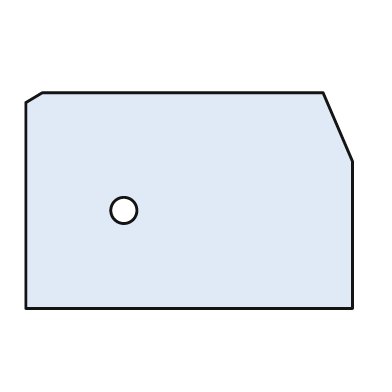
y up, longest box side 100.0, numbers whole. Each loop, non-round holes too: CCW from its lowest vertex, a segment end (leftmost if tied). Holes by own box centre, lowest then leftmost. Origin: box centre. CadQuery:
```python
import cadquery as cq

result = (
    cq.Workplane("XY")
    .moveTo(-50.0, -33.0)
    .lineTo(50.0, -33.0)
    .lineTo(50.0, 12.0)
    .lineTo(41.0, 33.0)
    .lineTo(-45.0, 33.0)
    .lineTo(-50.0, 30.0)
    .close()
    .moveTo(-20.0, -3.0)
    .circle(4.0)
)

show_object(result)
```